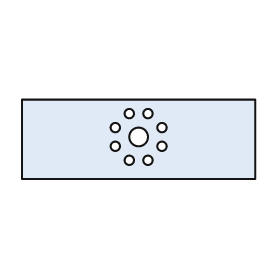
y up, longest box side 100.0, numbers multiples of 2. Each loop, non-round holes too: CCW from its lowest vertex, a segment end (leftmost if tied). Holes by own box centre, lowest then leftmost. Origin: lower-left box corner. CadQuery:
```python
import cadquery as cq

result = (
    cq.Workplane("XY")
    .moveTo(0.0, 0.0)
    .lineTo(100.0, 0.0)
    .lineTo(100.0, 34.0)
    .lineTo(0.0, 34.0)
    .close()
    .moveTo(46.0, 8.0)
    .circle(2.0)
    .moveTo(54.0, 8.0)
    .circle(2.0)
    .moveTo(40.0, 14.0)
    .circle(2.0)
    .moveTo(60.0, 14.0)
    .circle(2.0)
    .moveTo(50.0, 18.0)
    .circle(4.0)
    .moveTo(40.0, 22.0)
    .circle(2.0)
    .moveTo(60.0, 22.0)
    .circle(2.0)
    .moveTo(46.0, 28.0)
    .circle(2.0)
    .moveTo(54.0, 28.0)
    .circle(2.0)
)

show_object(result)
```